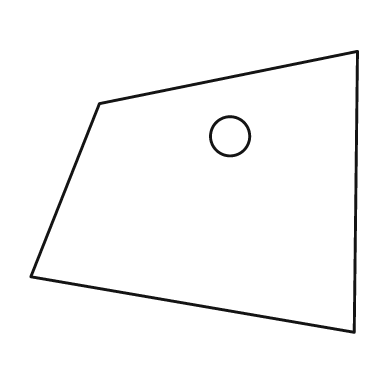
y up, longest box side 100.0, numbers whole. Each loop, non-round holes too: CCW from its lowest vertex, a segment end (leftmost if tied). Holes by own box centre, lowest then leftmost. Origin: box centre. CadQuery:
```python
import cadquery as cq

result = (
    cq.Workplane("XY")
    .moveTo(49.0, -43.0)
    .lineTo(50.0, 43.0)
    .lineTo(-29.0, 27.0)
    .lineTo(-50.0, -26.0)
    .close()
    .moveTo(11.0, 17.0)
    .circle(6.0)
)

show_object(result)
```